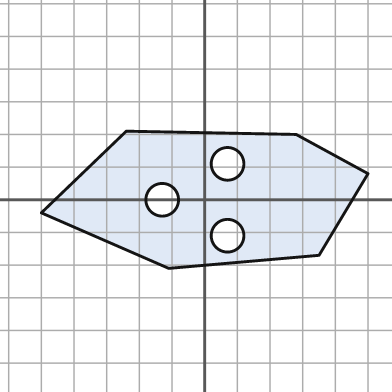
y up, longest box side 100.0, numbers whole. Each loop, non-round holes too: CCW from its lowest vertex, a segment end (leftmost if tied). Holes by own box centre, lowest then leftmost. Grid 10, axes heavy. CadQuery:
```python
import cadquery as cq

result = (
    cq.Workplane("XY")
    .moveTo(-11.0, -21.0)
    .lineTo(35.0, -17.0)
    .lineTo(50.0, 8.0)
    .lineTo(28.0, 20.0)
    .lineTo(-24.0, 21.0)
    .lineTo(-50.0, -4.0)
    .close()
    .moveTo(7.0, -11.0)
    .circle(5.0)
    .moveTo(-13.0, 0.0)
    .circle(5.0)
    .moveTo(7.0, 11.0)
    .circle(5.0)
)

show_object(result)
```